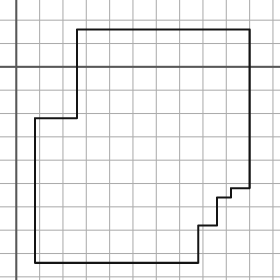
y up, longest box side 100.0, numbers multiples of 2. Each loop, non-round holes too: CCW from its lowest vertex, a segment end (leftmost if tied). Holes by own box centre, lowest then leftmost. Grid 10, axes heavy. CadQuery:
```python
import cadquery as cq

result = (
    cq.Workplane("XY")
    .moveTo(8.0, -84.0)
    .lineTo(78.0, -84.0)
    .lineTo(78.0, -68.0)
    .lineTo(86.0, -68.0)
    .lineTo(86.0, -56.0)
    .lineTo(92.0, -56.0)
    .lineTo(92.0, -52.0)
    .lineTo(100.0, -52.0)
    .lineTo(100.0, 16.0)
    .lineTo(26.0, 16.0)
    .lineTo(26.0, -22.0)
    .lineTo(8.0, -22.0)
    .close()
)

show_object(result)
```